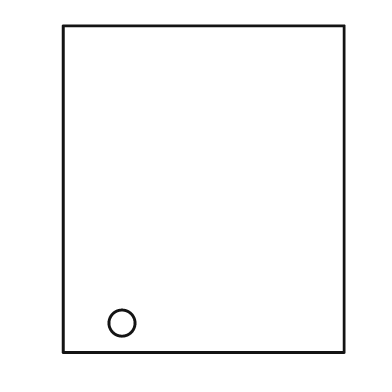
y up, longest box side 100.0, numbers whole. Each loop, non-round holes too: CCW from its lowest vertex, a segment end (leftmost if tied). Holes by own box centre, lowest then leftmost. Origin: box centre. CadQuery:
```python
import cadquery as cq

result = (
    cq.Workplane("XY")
    .moveTo(-43.0, -50.0)
    .lineTo(43.0, -50.0)
    .lineTo(43.0, 50.0)
    .lineTo(-43.0, 50.0)
    .close()
    .moveTo(-25.0, -41.0)
    .circle(4.0)
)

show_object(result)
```